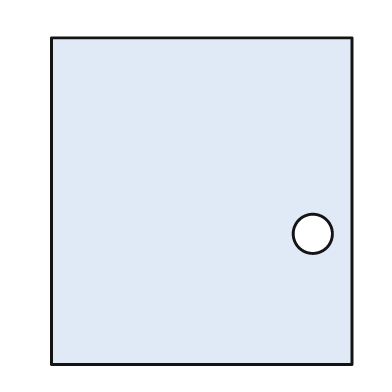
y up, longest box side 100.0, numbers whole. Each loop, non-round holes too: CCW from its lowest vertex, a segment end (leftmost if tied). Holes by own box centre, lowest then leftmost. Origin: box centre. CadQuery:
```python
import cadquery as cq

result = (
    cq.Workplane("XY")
    .moveTo(-46.0, -50.0)
    .lineTo(46.0, -50.0)
    .lineTo(46.0, 50.0)
    .lineTo(-46.0, 50.0)
    .close()
    .moveTo(34.0, -10.0)
    .circle(6.0)
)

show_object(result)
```